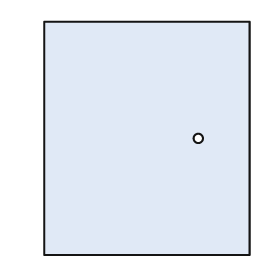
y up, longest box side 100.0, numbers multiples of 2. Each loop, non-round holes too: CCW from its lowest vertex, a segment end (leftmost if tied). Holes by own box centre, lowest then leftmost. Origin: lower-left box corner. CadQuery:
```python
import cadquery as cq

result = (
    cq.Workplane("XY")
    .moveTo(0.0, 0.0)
    .lineTo(88.0, 0.0)
    .lineTo(88.0, 100.0)
    .lineTo(0.0, 100.0)
    .close()
    .moveTo(66.0, 50.0)
    .circle(2.0)
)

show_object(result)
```